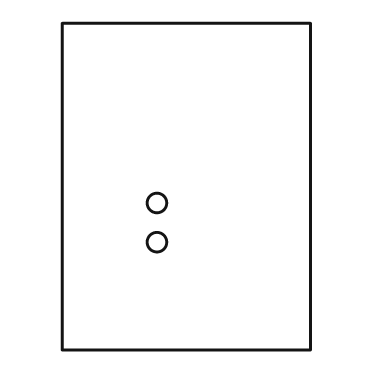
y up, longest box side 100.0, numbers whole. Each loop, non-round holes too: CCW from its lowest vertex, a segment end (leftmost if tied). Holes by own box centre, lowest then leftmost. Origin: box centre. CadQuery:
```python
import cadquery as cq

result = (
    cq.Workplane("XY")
    .moveTo(-38.0, -50.0)
    .lineTo(38.0, -50.0)
    .lineTo(38.0, 50.0)
    .lineTo(-38.0, 50.0)
    .close()
    .moveTo(-9.0, -17.0)
    .circle(3.0)
    .moveTo(-9.0, -5.0)
    .circle(3.0)
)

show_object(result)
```